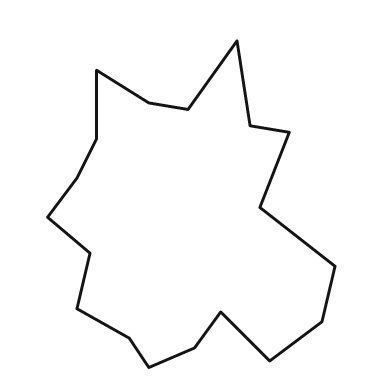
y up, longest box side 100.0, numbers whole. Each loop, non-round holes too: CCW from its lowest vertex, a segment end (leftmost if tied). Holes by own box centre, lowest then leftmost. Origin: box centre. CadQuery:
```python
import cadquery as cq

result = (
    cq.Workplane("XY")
    .moveTo(-13.0, -50.0)
    .lineTo(1.0, -44.0)
    .lineTo(9.0, -33.0)
    .lineTo(24.0, -48.0)
    .lineTo(40.0, -36.0)
    .lineTo(44.0, -19.0)
    .lineTo(21.0, -1.0)
    .lineTo(30.0, 22.0)
    .lineTo(18.0, 24.0)
    .lineTo(14.0, 50.0)
    .lineTo(-1.0, 29.0)
    .lineTo(-13.0, 31.0)
    .lineTo(-29.0, 41.0)
    .lineTo(-29.0, 20.0)
    .lineTo(-35.0, 8.0)
    .lineTo(-44.0, -4.0)
    .lineTo(-31.0, -15.0)
    .lineTo(-35.0, -32.0)
    .lineTo(-19.0, -41.0)
    .close()
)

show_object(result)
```